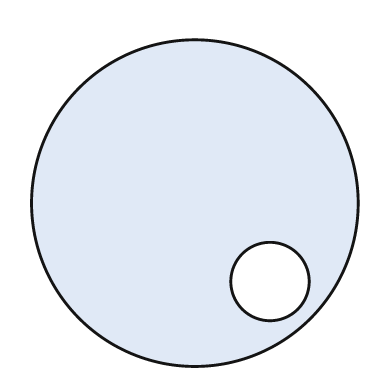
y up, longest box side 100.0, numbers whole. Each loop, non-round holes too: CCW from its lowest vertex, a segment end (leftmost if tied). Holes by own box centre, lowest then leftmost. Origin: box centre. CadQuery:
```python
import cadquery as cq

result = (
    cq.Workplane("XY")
    .moveTo(0.0, 0.0)
    .circle(50.0)
    .moveTo(23.0, -24.0)
    .circle(12.0)
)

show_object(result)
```